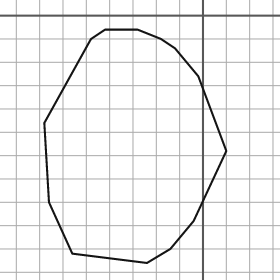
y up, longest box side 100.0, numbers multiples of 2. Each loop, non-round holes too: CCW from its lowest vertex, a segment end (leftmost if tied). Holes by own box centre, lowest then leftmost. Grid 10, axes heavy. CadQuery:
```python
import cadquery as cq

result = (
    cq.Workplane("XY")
    .moveTo(-24.0, -106.0)
    .lineTo(-14.0, -100.0)
    .lineTo(-4.0, -88.0)
    .lineTo(10.0, -58.0)
    .lineTo(-2.0, -26.0)
    .lineTo(-12.0, -14.0)
    .lineTo(-18.0, -10.0)
    .lineTo(-28.0, -6.0)
    .lineTo(-42.0, -6.0)
    .lineTo(-48.0, -10.0)
    .lineTo(-68.0, -46.0)
    .lineTo(-66.0, -80.0)
    .lineTo(-56.0, -102.0)
    .close()
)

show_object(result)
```